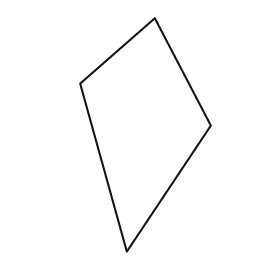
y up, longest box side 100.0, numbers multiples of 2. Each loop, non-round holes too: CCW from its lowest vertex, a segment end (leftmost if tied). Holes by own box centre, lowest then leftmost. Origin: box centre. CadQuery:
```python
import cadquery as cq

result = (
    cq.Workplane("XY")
    .moveTo(-8.0, -50.0)
    .lineTo(28.0, 4.0)
    .lineTo(4.0, 50.0)
    .lineTo(-28.0, 22.0)
    .close()
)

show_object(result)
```